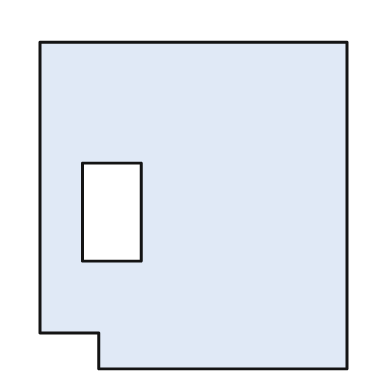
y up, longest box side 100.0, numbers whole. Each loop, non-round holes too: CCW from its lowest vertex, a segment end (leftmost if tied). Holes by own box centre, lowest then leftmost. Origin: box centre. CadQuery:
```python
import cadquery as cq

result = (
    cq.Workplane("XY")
    .moveTo(-29.0, -50.0)
    .lineTo(47.0, -50.0)
    .lineTo(47.0, 50.0)
    .lineTo(-47.0, 50.0)
    .lineTo(-47.0, -39.0)
    .lineTo(-29.0, -39.0)
    .close()
    .moveTo(-34.0, -17.0)
    .lineTo(-16.0, -17.0)
    .lineTo(-16.0, 13.0)
    .lineTo(-34.0, 13.0)
    .close()
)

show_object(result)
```